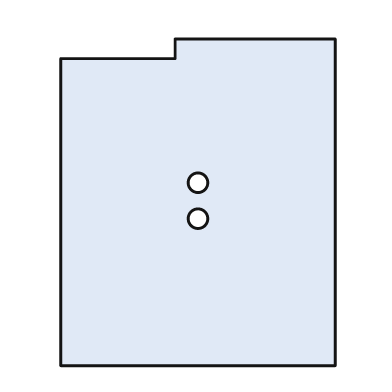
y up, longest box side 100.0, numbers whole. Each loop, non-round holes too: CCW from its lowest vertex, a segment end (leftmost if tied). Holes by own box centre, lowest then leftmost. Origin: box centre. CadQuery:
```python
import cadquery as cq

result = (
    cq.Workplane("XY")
    .moveTo(-42.0, -50.0)
    .lineTo(42.0, -50.0)
    .lineTo(42.0, 50.0)
    .lineTo(-7.0, 50.0)
    .lineTo(-7.0, 44.0)
    .lineTo(-42.0, 44.0)
    .close()
    .moveTo(0.0, -5.0)
    .circle(3.0)
    .moveTo(0.0, 6.0)
    .circle(3.0)
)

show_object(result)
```